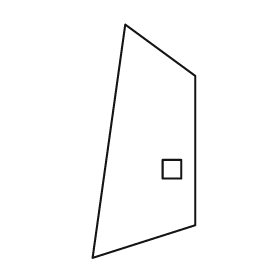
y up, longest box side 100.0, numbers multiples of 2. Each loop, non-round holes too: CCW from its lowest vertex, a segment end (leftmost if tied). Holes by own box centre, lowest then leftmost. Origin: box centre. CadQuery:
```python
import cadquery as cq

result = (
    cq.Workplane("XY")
    .moveTo(-22.0, -50.0)
    .lineTo(22.0, -36.0)
    .lineTo(22.0, 28.0)
    .lineTo(-8.0, 50.0)
    .close()
    .moveTo(8.0, -16.0)
    .lineTo(16.0, -16.0)
    .lineTo(16.0, -8.0)
    .lineTo(8.0, -8.0)
    .close()
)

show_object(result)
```